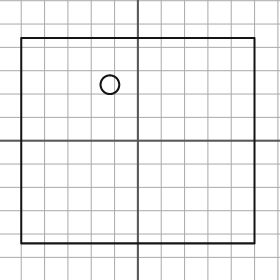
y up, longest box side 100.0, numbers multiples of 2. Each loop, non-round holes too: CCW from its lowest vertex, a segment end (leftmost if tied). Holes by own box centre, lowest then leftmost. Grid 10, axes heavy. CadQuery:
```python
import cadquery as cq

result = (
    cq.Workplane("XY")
    .moveTo(-50.0, -44.0)
    .lineTo(50.0, -44.0)
    .lineTo(50.0, 44.0)
    .lineTo(-50.0, 44.0)
    .close()
    .moveTo(-12.0, 24.0)
    .circle(4.0)
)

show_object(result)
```